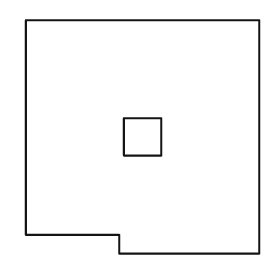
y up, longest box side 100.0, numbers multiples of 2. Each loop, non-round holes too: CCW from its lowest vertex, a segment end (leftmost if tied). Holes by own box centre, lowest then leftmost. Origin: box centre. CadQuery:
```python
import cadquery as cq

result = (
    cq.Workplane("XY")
    .moveTo(-10.0, -50.0)
    .lineTo(50.0, -50.0)
    .lineTo(50.0, 50.0)
    .lineTo(-50.0, 50.0)
    .lineTo(-50.0, -42.0)
    .lineTo(-10.0, -42.0)
    .close()
    .moveTo(-8.0, -8.0)
    .lineTo(8.0, -8.0)
    .lineTo(8.0, 8.0)
    .lineTo(-8.0, 8.0)
    .close()
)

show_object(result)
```